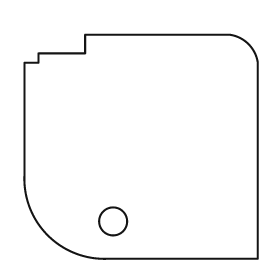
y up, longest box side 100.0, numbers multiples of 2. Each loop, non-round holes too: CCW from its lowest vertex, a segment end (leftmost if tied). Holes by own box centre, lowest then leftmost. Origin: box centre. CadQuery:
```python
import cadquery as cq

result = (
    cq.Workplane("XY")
    .moveTo(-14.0, -48.0)
    .lineTo(50.0, -48.0)
    .lineTo(50.0, 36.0)
    .threePointArc((46.0, 44.0), (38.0, 48.0))
    .lineTo(-24.0, 48.0)
    .lineTo(-24.0, 40.0)
    .lineTo(-44.0, 40.0)
    .lineTo(-44.0, 36.0)
    .lineTo(-50.0, 36.0)
    .lineTo(-50.0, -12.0)
    .threePointArc((-40.0, -38.0), (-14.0, -48.0))
    .close()
    .moveTo(-12.0, -32.0)
    .circle(6.0)
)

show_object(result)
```